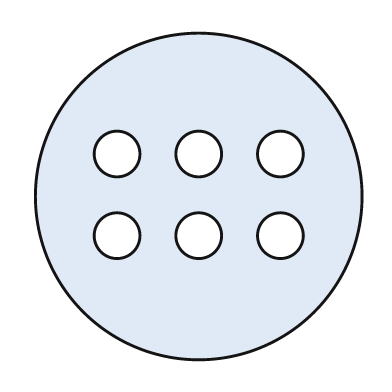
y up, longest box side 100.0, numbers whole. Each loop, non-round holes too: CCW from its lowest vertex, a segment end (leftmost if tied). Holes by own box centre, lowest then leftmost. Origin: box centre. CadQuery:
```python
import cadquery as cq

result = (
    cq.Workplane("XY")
    .moveTo(0.0, 0.0)
    .circle(50.0)
    .moveTo(-25.0, -12.0)
    .circle(7.0)
    .moveTo(0.0, -12.0)
    .circle(7.0)
    .moveTo(25.0, -12.0)
    .circle(7.0)
    .moveTo(-25.0, 13.0)
    .circle(7.0)
    .moveTo(0.0, 13.0)
    .circle(7.0)
    .moveTo(25.0, 13.0)
    .circle(7.0)
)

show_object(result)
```